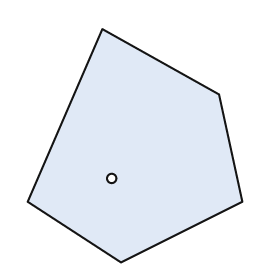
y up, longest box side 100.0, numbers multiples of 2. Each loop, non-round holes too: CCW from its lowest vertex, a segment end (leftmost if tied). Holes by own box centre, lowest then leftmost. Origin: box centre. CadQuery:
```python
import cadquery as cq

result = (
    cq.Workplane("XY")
    .moveTo(-6.0, -50.0)
    .lineTo(46.0, -24.0)
    .lineTo(36.0, 22.0)
    .lineTo(-14.0, 50.0)
    .lineTo(-46.0, -24.0)
    .close()
    .moveTo(-10.0, -14.0)
    .circle(2.0)
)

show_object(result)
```